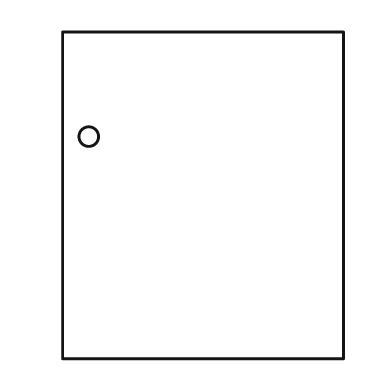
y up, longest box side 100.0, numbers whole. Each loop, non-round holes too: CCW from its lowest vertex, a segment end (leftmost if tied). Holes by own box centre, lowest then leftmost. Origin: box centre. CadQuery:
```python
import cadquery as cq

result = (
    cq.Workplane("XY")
    .moveTo(-43.0, -50.0)
    .lineTo(43.0, -50.0)
    .lineTo(43.0, 50.0)
    .lineTo(-43.0, 50.0)
    .close()
    .moveTo(-35.0, 18.0)
    .circle(3.0)
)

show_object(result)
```